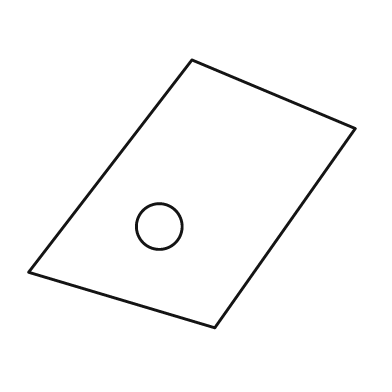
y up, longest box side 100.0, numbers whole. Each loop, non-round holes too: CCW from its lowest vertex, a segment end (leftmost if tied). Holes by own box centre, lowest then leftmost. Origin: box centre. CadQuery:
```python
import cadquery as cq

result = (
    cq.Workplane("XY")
    .moveTo(7.0, -41.0)
    .lineTo(50.0, 20.0)
    .lineTo(0.0, 41.0)
    .lineTo(-50.0, -24.0)
    .close()
    .moveTo(-10.0, -10.0)
    .circle(7.0)
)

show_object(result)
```